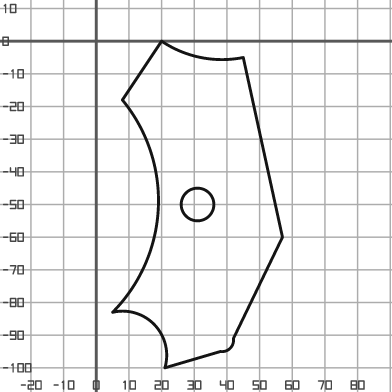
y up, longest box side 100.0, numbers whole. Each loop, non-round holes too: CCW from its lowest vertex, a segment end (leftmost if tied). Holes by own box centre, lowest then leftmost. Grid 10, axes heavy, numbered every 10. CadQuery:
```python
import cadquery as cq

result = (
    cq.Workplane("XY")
    .moveTo(21.0, -100.0)
    .lineTo(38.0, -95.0)
    .threePointArc((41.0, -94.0), (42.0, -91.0))
    .lineTo(57.0, -60.0)
    .lineTo(45.0, -5.0)
    .threePointArc((32.0, -5.0), (20.0, 0.0))
    .lineTo(8.0, -18.0)
    .threePointArc((19.0, -51.0), (5.0, -83.0))
    .threePointArc((18.0, -87.0), (21.0, -100.0))
    .close()
    .moveTo(31.0, -50.0)
    .circle(5.0)
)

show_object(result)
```